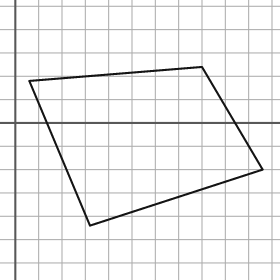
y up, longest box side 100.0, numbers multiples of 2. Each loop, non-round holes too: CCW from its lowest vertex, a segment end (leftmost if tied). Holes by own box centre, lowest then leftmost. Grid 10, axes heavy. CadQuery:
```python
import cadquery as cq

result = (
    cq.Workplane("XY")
    .moveTo(32.0, -44.0)
    .lineTo(106.0, -20.0)
    .lineTo(80.0, 24.0)
    .lineTo(6.0, 18.0)
    .close()
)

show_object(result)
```